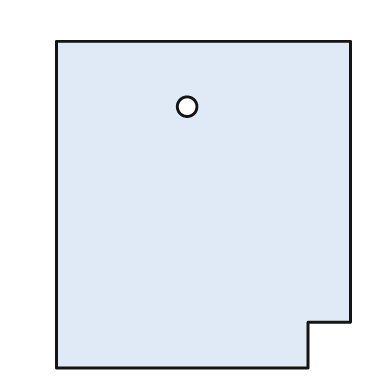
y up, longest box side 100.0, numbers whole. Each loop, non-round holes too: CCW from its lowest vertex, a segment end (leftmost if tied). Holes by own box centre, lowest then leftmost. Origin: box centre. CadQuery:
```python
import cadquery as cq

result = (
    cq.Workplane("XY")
    .moveTo(-45.0, -50.0)
    .lineTo(32.0, -50.0)
    .lineTo(32.0, -36.0)
    .lineTo(45.0, -36.0)
    .lineTo(45.0, 50.0)
    .lineTo(-45.0, 50.0)
    .close()
    .moveTo(-5.0, 30.0)
    .circle(3.0)
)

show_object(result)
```